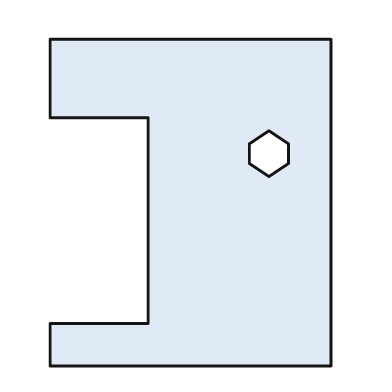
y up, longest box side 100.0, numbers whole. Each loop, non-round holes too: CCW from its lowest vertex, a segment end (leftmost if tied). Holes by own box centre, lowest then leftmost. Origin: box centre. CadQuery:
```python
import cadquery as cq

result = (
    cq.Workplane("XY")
    .moveTo(-43.0, -50.0)
    .lineTo(43.0, -50.0)
    .lineTo(43.0, 50.0)
    .lineTo(-43.0, 50.0)
    .lineTo(-43.0, 26.0)
    .lineTo(-13.0, 26.0)
    .lineTo(-13.0, -37.0)
    .lineTo(-43.0, -37.0)
    .close()
    .moveTo(24.0, 8.0)
    .lineTo(30.0, 12.0)
    .lineTo(30.0, 18.0)
    .lineTo(24.0, 22.0)
    .lineTo(18.0, 18.0)
    .lineTo(18.0, 12.0)
    .close()
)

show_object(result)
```